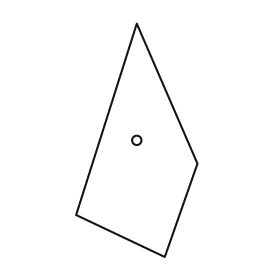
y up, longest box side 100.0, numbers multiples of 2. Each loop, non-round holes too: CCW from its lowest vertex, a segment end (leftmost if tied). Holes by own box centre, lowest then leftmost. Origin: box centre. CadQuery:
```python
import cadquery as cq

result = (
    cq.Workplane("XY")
    .moveTo(12.0, -50.0)
    .lineTo(26.0, -10.0)
    .lineTo(0.0, 50.0)
    .lineTo(-26.0, -32.0)
    .close()
    .moveTo(0.0, 0.0)
    .circle(2.0)
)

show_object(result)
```